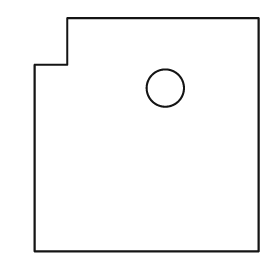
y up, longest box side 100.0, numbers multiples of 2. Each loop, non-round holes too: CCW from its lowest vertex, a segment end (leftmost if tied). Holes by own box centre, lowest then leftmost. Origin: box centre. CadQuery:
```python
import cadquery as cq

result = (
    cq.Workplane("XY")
    .moveTo(-48.0, -50.0)
    .lineTo(48.0, -50.0)
    .lineTo(48.0, 50.0)
    .lineTo(-34.0, 50.0)
    .lineTo(-34.0, 30.0)
    .lineTo(-48.0, 30.0)
    .close()
    .moveTo(8.0, 20.0)
    .circle(8.0)
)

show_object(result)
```